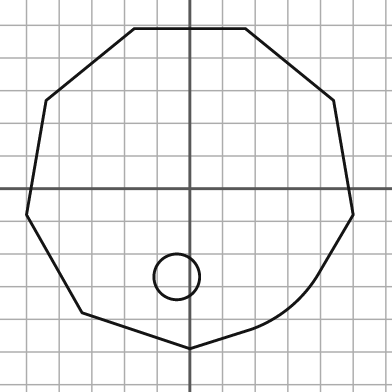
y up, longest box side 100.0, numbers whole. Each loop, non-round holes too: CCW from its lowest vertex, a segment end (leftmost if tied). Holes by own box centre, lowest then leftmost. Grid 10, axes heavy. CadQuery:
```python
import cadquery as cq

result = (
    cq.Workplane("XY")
    .moveTo(0.0, -49.0)
    .lineTo(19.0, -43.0)
    .threePointArc((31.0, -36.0), (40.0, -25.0))
    .lineTo(50.0, -8.0)
    .lineTo(44.0, 27.0)
    .lineTo(17.0, 49.0)
    .lineTo(-17.0, 49.0)
    .lineTo(-44.0, 27.0)
    .lineTo(-50.0, -8.0)
    .lineTo(-33.0, -38.0)
    .close()
    .moveTo(-4.0, -27.0)
    .circle(7.0)
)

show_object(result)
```